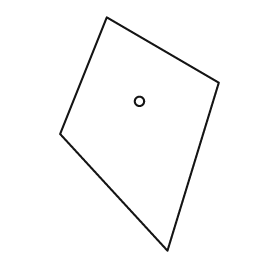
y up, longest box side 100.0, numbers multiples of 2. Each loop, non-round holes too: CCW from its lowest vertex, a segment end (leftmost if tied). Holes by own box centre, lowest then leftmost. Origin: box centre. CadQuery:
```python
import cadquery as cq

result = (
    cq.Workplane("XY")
    .moveTo(12.0, -50.0)
    .lineTo(34.0, 22.0)
    .lineTo(-14.0, 50.0)
    .lineTo(-34.0, 0.0)
    .close()
    .moveTo(0.0, 14.0)
    .circle(2.0)
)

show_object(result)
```